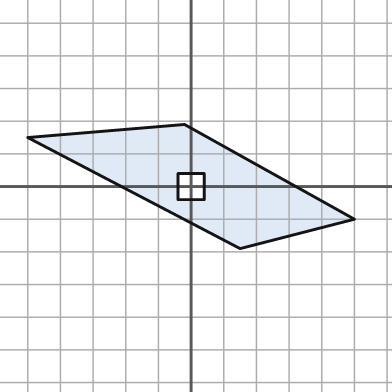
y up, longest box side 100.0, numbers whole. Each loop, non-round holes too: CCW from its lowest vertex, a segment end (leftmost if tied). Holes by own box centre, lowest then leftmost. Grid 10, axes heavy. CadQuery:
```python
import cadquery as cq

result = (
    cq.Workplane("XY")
    .moveTo(15.0, -19.0)
    .lineTo(50.0, -10.0)
    .lineTo(-2.0, 19.0)
    .lineTo(-50.0, 15.0)
    .close()
    .moveTo(-4.0, -4.0)
    .lineTo(4.0, -4.0)
    .lineTo(4.0, 4.0)
    .lineTo(-4.0, 4.0)
    .close()
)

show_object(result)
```